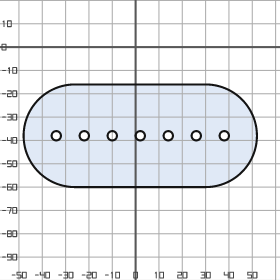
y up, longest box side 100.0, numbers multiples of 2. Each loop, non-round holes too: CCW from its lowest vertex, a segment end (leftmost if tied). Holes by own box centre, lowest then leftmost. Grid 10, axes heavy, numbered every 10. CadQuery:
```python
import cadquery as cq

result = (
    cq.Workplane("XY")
    .moveTo(-26.0, -60.0)
    .lineTo(30.0, -60.0)
    .threePointArc((52.0, -38.0), (30.0, -16.0))
    .lineTo(-26.0, -16.0)
    .threePointArc((-48.0, -38.0), (-26.0, -60.0))
    .close()
    .moveTo(-34.0, -38.0)
    .circle(2.0)
    .moveTo(-22.0, -38.0)
    .circle(2.0)
    .moveTo(-10.0, -38.0)
    .circle(2.0)
    .moveTo(2.0, -38.0)
    .circle(2.0)
    .moveTo(14.0, -38.0)
    .circle(2.0)
    .moveTo(26.0, -38.0)
    .circle(2.0)
    .moveTo(38.0, -38.0)
    .circle(2.0)
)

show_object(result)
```